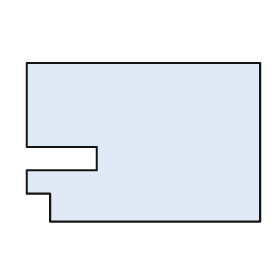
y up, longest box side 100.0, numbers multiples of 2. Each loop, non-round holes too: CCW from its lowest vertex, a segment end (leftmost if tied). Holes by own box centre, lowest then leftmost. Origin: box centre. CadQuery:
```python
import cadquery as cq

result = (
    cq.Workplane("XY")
    .moveTo(-40.0, -34.0)
    .lineTo(50.0, -34.0)
    .lineTo(50.0, 34.0)
    .lineTo(-50.0, 34.0)
    .lineTo(-50.0, -2.0)
    .lineTo(-20.0, -2.0)
    .lineTo(-20.0, -12.0)
    .lineTo(-50.0, -12.0)
    .lineTo(-50.0, -22.0)
    .lineTo(-40.0, -22.0)
    .close()
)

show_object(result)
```